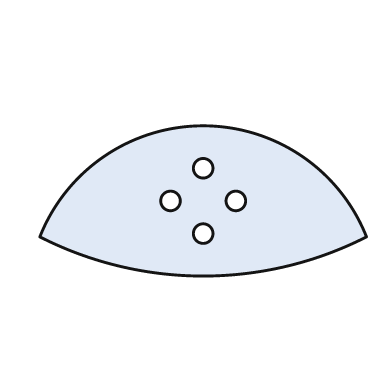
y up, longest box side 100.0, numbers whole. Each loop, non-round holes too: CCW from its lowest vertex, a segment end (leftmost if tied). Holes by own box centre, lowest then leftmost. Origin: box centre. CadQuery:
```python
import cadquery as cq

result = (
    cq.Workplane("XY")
    .moveTo(-50.0, -11.0)
    .threePointArc((0.0, -23.0), (50.0, -11.0))
    .threePointArc((0.0, 23.0), (-50.0, -11.0))
    .close()
    .moveTo(0.0, -10.0)
    .circle(3.0)
    .moveTo(-10.0, 0.0)
    .circle(3.0)
    .moveTo(10.0, 0.0)
    .circle(3.0)
    .moveTo(0.0, 10.0)
    .circle(3.0)
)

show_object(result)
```